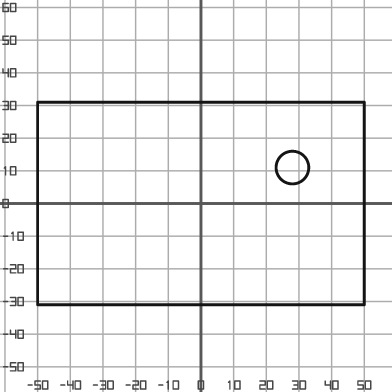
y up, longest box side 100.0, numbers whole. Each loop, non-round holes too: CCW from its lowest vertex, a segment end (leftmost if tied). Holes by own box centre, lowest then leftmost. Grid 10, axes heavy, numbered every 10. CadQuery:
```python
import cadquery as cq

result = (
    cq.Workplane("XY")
    .moveTo(-50.0, -31.0)
    .lineTo(50.0, -31.0)
    .lineTo(50.0, 31.0)
    .lineTo(-50.0, 31.0)
    .close()
    .moveTo(28.0, 11.0)
    .circle(5.0)
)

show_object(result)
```